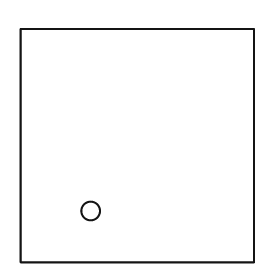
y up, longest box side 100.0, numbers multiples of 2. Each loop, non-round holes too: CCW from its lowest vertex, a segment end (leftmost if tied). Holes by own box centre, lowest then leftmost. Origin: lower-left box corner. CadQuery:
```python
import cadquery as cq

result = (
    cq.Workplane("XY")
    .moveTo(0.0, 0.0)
    .lineTo(100.0, 0.0)
    .lineTo(100.0, 100.0)
    .lineTo(0.0, 100.0)
    .close()
    .moveTo(30.0, 22.0)
    .circle(4.0)
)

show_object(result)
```